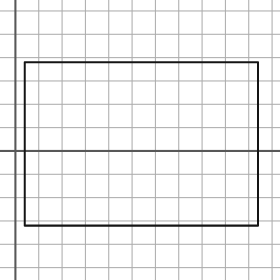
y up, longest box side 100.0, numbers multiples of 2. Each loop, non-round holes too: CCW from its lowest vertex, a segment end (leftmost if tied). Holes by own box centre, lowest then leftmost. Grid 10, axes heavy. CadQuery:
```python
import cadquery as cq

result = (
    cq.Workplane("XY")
    .moveTo(4.0, -32.0)
    .lineTo(104.0, -32.0)
    .lineTo(104.0, 38.0)
    .lineTo(4.0, 38.0)
    .close()
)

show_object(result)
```